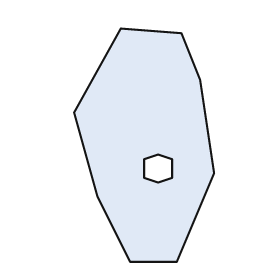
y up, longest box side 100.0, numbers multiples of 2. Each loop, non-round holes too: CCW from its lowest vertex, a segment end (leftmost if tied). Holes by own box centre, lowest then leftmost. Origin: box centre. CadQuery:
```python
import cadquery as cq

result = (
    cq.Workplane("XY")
    .moveTo(-6.0, -50.0)
    .lineTo(14.0, -50.0)
    .lineTo(30.0, -12.0)
    .lineTo(24.0, 28.0)
    .lineTo(16.0, 48.0)
    .lineTo(-10.0, 50.0)
    .lineTo(-30.0, 14.0)
    .lineTo(-20.0, -22.0)
    .close()
    .moveTo(6.0, -16.0)
    .lineTo(12.0, -14.0)
    .lineTo(12.0, -6.0)
    .lineTo(6.0, -4.0)
    .lineTo(0.0, -6.0)
    .lineTo(0.0, -14.0)
    .close()
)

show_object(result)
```